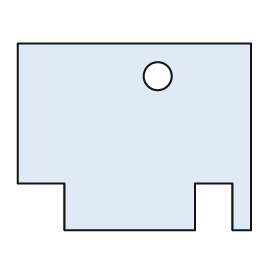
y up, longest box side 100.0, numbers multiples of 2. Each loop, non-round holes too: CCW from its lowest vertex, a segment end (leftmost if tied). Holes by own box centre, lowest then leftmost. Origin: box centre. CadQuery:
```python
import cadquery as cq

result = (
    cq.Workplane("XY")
    .moveTo(-30.0, -40.0)
    .lineTo(26.0, -40.0)
    .lineTo(26.0, -20.0)
    .lineTo(42.0, -20.0)
    .lineTo(42.0, -40.0)
    .lineTo(50.0, -40.0)
    .lineTo(50.0, 40.0)
    .lineTo(-50.0, 40.0)
    .lineTo(-50.0, -20.0)
    .lineTo(-30.0, -20.0)
    .close()
    .moveTo(10.0, 26.0)
    .circle(6.0)
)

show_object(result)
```